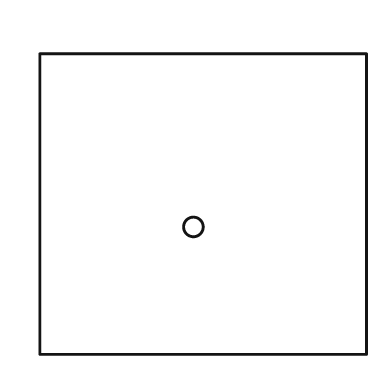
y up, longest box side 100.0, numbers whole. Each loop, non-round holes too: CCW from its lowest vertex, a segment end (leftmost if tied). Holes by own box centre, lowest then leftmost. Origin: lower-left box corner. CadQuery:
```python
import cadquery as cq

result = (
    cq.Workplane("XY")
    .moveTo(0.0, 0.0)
    .lineTo(100.0, 0.0)
    .lineTo(100.0, 92.0)
    .lineTo(0.0, 92.0)
    .close()
    .moveTo(47.0, 39.0)
    .circle(3.0)
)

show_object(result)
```